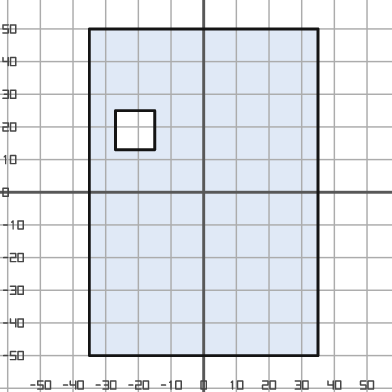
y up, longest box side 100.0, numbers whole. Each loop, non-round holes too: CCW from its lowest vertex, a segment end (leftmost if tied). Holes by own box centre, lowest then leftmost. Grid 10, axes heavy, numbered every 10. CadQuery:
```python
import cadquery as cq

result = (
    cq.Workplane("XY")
    .moveTo(-35.0, -50.0)
    .lineTo(35.0, -50.0)
    .lineTo(35.0, 50.0)
    .lineTo(-35.0, 50.0)
    .close()
    .moveTo(-27.0, 13.0)
    .lineTo(-15.0, 13.0)
    .lineTo(-15.0, 25.0)
    .lineTo(-27.0, 25.0)
    .close()
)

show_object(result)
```